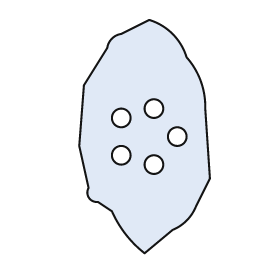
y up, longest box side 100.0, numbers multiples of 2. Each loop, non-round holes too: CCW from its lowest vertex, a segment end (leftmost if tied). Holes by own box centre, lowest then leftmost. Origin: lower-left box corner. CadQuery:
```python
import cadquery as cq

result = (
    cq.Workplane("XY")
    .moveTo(28.0, 0.0)
    .lineTo(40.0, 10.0)
    .threePointArc((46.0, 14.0), (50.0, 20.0))
    .lineTo(56.0, 32.0)
    .lineTo(54.0, 62.0)
    .threePointArc((52.0, 74.0), (46.0, 84.0))
    .threePointArc((40.0, 94.0), (30.0, 100.0))
    .lineTo(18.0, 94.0)
    .threePointArc((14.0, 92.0), (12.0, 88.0))
    .lineTo(2.0, 72.0)
    .lineTo(0.0, 46.0)
    .lineTo(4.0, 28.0)
    .threePointArc((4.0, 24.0), (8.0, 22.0))
    .lineTo(14.0, 18.0)
    .threePointArc((20.0, 8.0), (28.0, 0.0))
    .close()
    .moveTo(32.0, 38.0)
    .circle(4.0)
    .moveTo(18.0, 42.0)
    .circle(4.0)
    .moveTo(42.0, 50.0)
    .circle(4.0)
    .moveTo(18.0, 58.0)
    .circle(4.0)
    .moveTo(32.0, 62.0)
    .circle(4.0)
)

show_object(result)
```